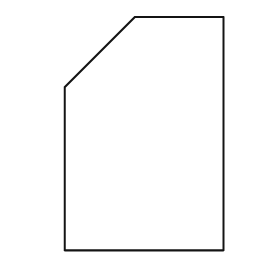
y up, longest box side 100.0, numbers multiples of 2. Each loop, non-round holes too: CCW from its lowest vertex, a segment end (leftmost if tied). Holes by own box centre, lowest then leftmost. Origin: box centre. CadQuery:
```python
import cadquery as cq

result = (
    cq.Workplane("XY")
    .moveTo(-34.0, -50.0)
    .lineTo(34.0, -50.0)
    .lineTo(34.0, 50.0)
    .lineTo(-4.0, 50.0)
    .lineTo(-34.0, 20.0)
    .close()
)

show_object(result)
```